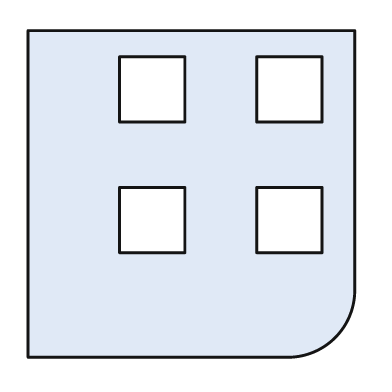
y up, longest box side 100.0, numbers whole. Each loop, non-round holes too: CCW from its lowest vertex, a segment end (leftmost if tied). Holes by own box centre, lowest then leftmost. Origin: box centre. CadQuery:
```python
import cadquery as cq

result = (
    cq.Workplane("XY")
    .moveTo(-50.0, -50.0)
    .lineTo(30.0, -50.0)
    .threePointArc((44.0, -44.0), (50.0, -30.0))
    .lineTo(50.0, 50.0)
    .lineTo(-50.0, 50.0)
    .close()
    .moveTo(-22.0, -18.0)
    .lineTo(-2.0, -18.0)
    .lineTo(-2.0, 2.0)
    .lineTo(-22.0, 2.0)
    .close()
    .moveTo(20.0, -18.0)
    .lineTo(40.0, -18.0)
    .lineTo(40.0, 2.0)
    .lineTo(20.0, 2.0)
    .close()
    .moveTo(-22.0, 22.0)
    .lineTo(-2.0, 22.0)
    .lineTo(-2.0, 42.0)
    .lineTo(-22.0, 42.0)
    .close()
    .moveTo(20.0, 22.0)
    .lineTo(40.0, 22.0)
    .lineTo(40.0, 42.0)
    .lineTo(20.0, 42.0)
    .close()
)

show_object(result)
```